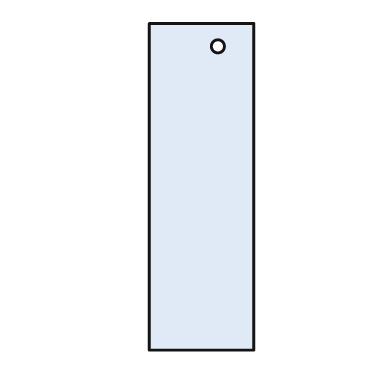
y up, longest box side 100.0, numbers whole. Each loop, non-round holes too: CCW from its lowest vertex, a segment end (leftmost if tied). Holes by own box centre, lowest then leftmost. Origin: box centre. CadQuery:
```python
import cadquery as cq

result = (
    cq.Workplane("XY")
    .moveTo(-16.0, -50.0)
    .lineTo(16.0, -50.0)
    .lineTo(16.0, 50.0)
    .lineTo(-16.0, 50.0)
    .close()
    .moveTo(5.0, 43.0)
    .circle(2.0)
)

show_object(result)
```